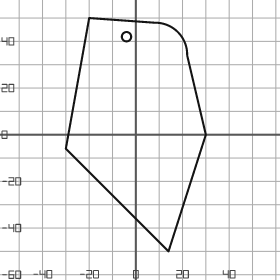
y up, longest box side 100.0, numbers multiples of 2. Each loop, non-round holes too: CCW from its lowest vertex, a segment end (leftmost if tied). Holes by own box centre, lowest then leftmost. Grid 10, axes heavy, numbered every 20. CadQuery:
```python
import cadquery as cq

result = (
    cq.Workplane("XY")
    .moveTo(14.0, -50.0)
    .lineTo(30.0, 0.0)
    .lineTo(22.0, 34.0)
    .threePointArc((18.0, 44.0), (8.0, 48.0))
    .lineTo(-20.0, 50.0)
    .lineTo(-30.0, -6.0)
    .close()
    .moveTo(-4.0, 42.0)
    .circle(2.0)
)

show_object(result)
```